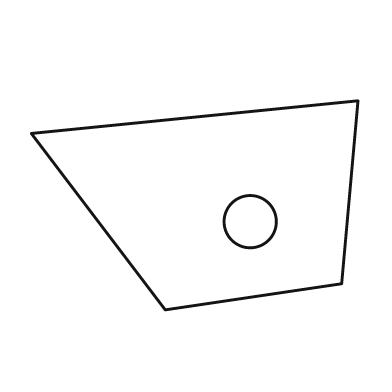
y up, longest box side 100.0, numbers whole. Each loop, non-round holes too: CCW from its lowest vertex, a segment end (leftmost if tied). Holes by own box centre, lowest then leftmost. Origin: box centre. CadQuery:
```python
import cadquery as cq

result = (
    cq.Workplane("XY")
    .moveTo(-9.0, -32.0)
    .lineTo(45.0, -24.0)
    .lineTo(50.0, 32.0)
    .lineTo(-50.0, 22.0)
    .close()
    .moveTo(17.0, -5.0)
    .circle(8.0)
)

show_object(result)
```